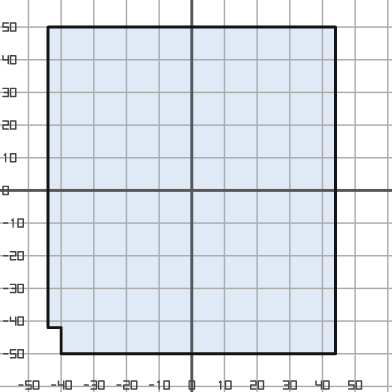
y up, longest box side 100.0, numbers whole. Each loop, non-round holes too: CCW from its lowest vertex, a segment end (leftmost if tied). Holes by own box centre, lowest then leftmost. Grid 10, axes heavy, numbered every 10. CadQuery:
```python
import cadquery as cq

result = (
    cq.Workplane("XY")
    .moveTo(-40.0, -50.0)
    .lineTo(44.0, -50.0)
    .lineTo(44.0, 50.0)
    .lineTo(-44.0, 50.0)
    .lineTo(-44.0, -42.0)
    .lineTo(-40.0, -42.0)
    .close()
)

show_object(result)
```